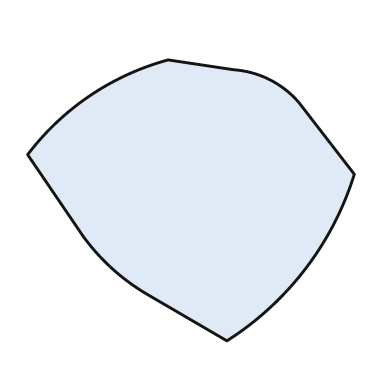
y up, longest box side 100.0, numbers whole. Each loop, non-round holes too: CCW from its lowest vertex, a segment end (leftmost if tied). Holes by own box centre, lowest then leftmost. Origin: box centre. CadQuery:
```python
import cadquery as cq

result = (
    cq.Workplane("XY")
    .moveTo(11.0, -43.0)
    .threePointArc((35.0, -21.0), (50.0, 8.0))
    .lineTo(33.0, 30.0)
    .threePointArc((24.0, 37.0), (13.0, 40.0))
    .lineTo(-7.0, 43.0)
    .threePointArc((-31.0, 32.0), (-50.0, 14.0))
    .lineTo(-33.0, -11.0)
    .threePointArc((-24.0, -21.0), (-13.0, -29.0))
    .close()
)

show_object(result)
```